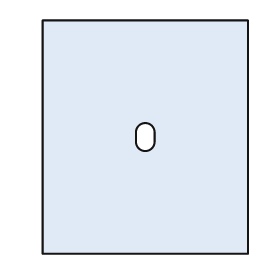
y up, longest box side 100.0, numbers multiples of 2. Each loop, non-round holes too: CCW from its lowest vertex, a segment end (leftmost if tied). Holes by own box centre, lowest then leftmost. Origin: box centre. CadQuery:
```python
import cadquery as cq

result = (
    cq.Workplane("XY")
    .moveTo(-44.0, -50.0)
    .lineTo(44.0, -50.0)
    .lineTo(44.0, 50.0)
    .lineTo(-44.0, 50.0)
    .close()
    .moveTo(-4.0, -2.0)
    .threePointArc((0.0, -6.0), (4.0, -2.0))
    .lineTo(4.0, 2.0)
    .threePointArc((0.0, 6.0), (-4.0, 2.0))
    .close()
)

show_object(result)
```